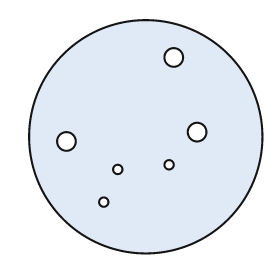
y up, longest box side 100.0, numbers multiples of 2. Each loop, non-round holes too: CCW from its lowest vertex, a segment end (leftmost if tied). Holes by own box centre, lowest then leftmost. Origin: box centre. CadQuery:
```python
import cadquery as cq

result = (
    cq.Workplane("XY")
    .moveTo(0.0, 0.0)
    .circle(50.0)
    .moveTo(-18.0, -28.0)
    .circle(2.0)
    .moveTo(-12.0, -14.0)
    .circle(2.0)
    .moveTo(10.0, -12.0)
    .circle(2.0)
    .moveTo(-34.0, -2.0)
    .circle(4.0)
    .moveTo(22.0, 2.0)
    .circle(4.0)
    .moveTo(12.0, 34.0)
    .circle(4.0)
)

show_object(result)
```